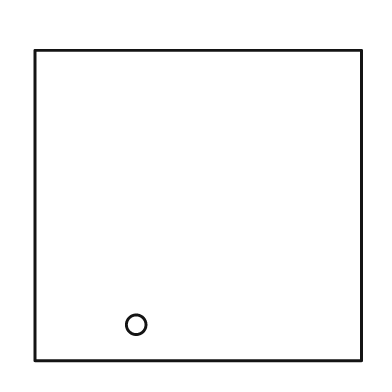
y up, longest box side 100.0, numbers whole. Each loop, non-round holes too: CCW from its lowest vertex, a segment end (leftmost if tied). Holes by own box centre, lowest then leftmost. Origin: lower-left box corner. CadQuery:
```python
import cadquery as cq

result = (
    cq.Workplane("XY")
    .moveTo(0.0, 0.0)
    .lineTo(100.0, 0.0)
    .lineTo(100.0, 95.0)
    .lineTo(0.0, 95.0)
    .close()
    .moveTo(31.0, 11.0)
    .circle(3.0)
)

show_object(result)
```